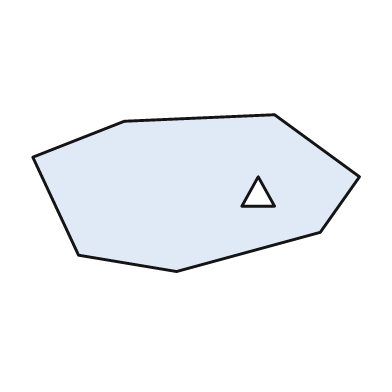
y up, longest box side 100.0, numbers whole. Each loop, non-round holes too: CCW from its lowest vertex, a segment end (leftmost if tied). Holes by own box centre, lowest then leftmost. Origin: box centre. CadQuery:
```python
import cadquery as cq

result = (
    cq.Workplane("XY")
    .moveTo(-6.0, -24.0)
    .lineTo(38.0, -12.0)
    .lineTo(50.0, 5.0)
    .lineTo(24.0, 24.0)
    .lineTo(-22.0, 22.0)
    .lineTo(-50.0, 11.0)
    .lineTo(-36.0, -19.0)
    .close()
    .moveTo(14.0, -4.0)
    .lineTo(24.0, -4.0)
    .lineTo(19.0, 5.0)
    .close()
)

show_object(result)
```